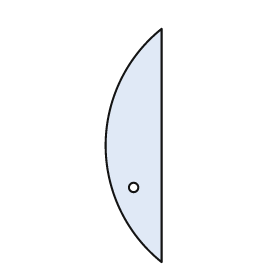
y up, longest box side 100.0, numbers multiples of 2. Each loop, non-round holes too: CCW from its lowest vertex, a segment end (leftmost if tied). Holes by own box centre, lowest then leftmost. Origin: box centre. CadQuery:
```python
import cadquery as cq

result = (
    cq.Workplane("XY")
    .moveTo(12.0, -50.0)
    .lineTo(12.0, 50.0)
    .threePointArc((-12.0, 0.0), (12.0, -50.0))
    .close()
    .moveTo(0.0, -18.0)
    .circle(2.0)
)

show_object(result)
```